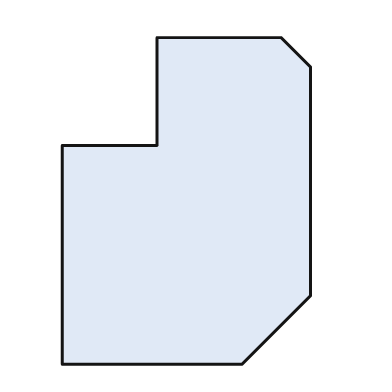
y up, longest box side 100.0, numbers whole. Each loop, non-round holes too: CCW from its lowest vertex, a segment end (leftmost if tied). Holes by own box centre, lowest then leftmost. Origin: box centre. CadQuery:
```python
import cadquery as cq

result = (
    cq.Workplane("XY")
    .moveTo(-38.0, -50.0)
    .lineTo(17.0, -50.0)
    .lineTo(38.0, -29.0)
    .lineTo(38.0, 41.0)
    .lineTo(29.0, 50.0)
    .lineTo(-9.0, 50.0)
    .lineTo(-9.0, 17.0)
    .lineTo(-38.0, 17.0)
    .close()
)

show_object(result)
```